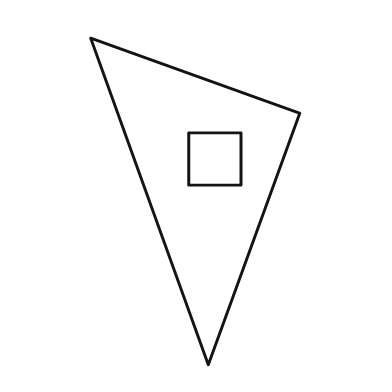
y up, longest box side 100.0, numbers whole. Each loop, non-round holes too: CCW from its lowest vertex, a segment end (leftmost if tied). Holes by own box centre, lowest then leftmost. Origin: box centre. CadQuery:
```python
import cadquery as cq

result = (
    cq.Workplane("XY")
    .moveTo(4.0, -50.0)
    .lineTo(32.0, 27.0)
    .lineTo(-32.0, 50.0)
    .close()
    .moveTo(-2.0, 5.0)
    .lineTo(14.0, 5.0)
    .lineTo(14.0, 21.0)
    .lineTo(-2.0, 21.0)
    .close()
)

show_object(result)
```